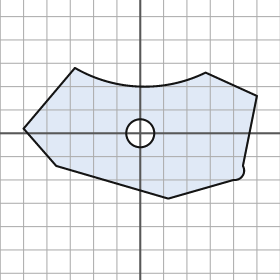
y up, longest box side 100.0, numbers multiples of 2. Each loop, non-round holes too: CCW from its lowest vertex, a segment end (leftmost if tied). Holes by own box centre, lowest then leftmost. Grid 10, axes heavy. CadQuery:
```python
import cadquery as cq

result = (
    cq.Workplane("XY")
    .moveTo(12.0, -28.0)
    .lineTo(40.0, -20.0)
    .threePointArc((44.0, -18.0), (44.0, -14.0))
    .lineTo(50.0, 16.0)
    .lineTo(28.0, 26.0)
    .threePointArc((0.0, 20.0), (-28.0, 28.0))
    .lineTo(-50.0, 2.0)
    .lineTo(-36.0, -14.0)
    .close()
    .moveTo(0.0, 0.0)
    .circle(6.0)
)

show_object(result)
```